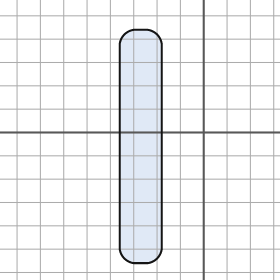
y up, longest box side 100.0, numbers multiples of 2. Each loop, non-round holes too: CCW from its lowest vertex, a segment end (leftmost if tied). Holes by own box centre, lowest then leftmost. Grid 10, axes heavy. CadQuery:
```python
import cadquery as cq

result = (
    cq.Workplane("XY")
    .moveTo(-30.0, -56.0)
    .lineTo(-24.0, -56.0)
    .threePointArc((-20.0, -54.0), (-18.0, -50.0))
    .lineTo(-18.0, 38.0)
    .threePointArc((-20.0, 42.0), (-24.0, 44.0))
    .lineTo(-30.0, 44.0)
    .threePointArc((-34.0, 42.0), (-36.0, 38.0))
    .lineTo(-36.0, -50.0)
    .threePointArc((-34.0, -54.0), (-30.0, -56.0))
    .close()
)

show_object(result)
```